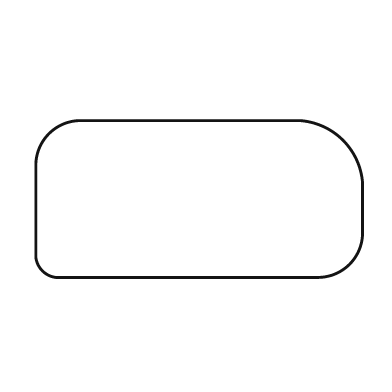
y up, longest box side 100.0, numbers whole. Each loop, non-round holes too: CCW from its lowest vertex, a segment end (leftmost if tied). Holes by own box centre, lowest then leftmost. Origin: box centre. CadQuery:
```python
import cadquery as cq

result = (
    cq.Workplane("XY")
    .moveTo(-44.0, -24.0)
    .lineTo(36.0, -24.0)
    .threePointArc((46.0, -20.0), (50.0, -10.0))
    .lineTo(50.0, 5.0)
    .threePointArc((44.0, 18.0), (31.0, 24.0))
    .lineTo(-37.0, 24.0)
    .threePointArc((-46.0, 20.0), (-50.0, 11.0))
    .lineTo(-50.0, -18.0)
    .threePointArc((-48.0, -22.0), (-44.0, -24.0))
    .close()
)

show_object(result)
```